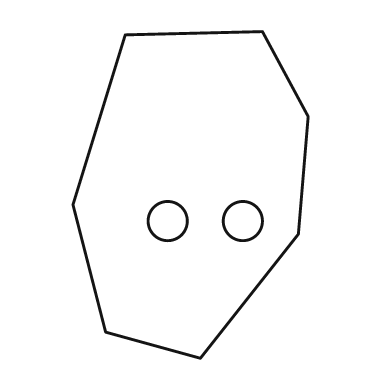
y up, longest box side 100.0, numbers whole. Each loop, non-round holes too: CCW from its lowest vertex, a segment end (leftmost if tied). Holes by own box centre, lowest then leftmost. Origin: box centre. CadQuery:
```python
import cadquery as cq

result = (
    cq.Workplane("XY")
    .moveTo(3.0, -50.0)
    .lineTo(33.0, -12.0)
    .lineTo(36.0, 24.0)
    .lineTo(22.0, 50.0)
    .lineTo(-20.0, 49.0)
    .lineTo(-36.0, -3.0)
    .lineTo(-26.0, -42.0)
    .close()
    .moveTo(-7.0, -8.0)
    .circle(6.0)
    .moveTo(16.0, -8.0)
    .circle(6.0)
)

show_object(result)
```